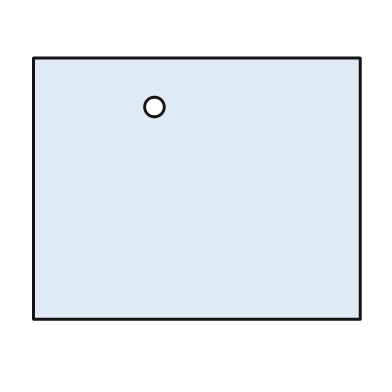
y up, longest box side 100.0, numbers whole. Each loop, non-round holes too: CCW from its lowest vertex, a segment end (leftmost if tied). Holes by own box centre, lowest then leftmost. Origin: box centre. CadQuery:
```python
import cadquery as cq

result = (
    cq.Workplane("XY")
    .moveTo(-50.0, -40.0)
    .lineTo(50.0, -40.0)
    .lineTo(50.0, 40.0)
    .lineTo(-50.0, 40.0)
    .close()
    .moveTo(-13.0, 25.0)
    .circle(3.0)
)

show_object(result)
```